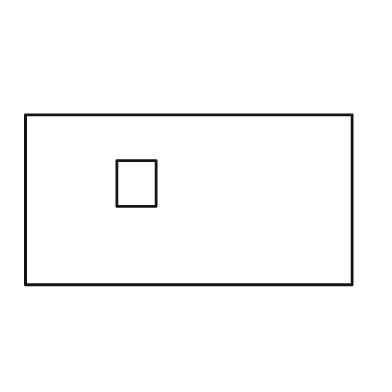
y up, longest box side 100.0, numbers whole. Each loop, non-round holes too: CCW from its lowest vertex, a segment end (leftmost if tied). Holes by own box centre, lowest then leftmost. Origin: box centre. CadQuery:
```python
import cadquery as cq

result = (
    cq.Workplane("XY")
    .moveTo(-50.0, -26.0)
    .lineTo(50.0, -26.0)
    .lineTo(50.0, 26.0)
    .lineTo(-50.0, 26.0)
    .close()
    .moveTo(-22.0, -2.0)
    .lineTo(-10.0, -2.0)
    .lineTo(-10.0, 12.0)
    .lineTo(-22.0, 12.0)
    .close()
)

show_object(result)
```